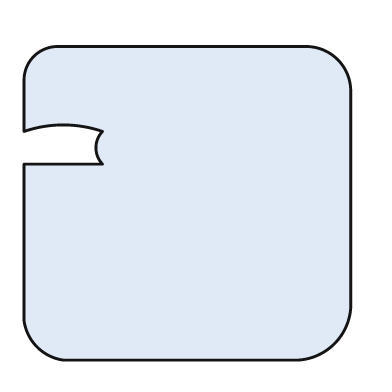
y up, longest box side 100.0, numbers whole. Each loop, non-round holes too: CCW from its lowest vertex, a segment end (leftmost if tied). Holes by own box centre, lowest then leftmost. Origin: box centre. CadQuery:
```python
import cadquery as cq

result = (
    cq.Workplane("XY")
    .moveTo(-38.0, -48.0)
    .lineTo(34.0, -48.0)
    .threePointArc((45.0, -43.0), (50.0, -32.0))
    .lineTo(50.0, 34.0)
    .threePointArc((46.0, 44.0), (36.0, 48.0))
    .lineTo(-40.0, 48.0)
    .threePointArc((-47.0, 45.0), (-50.0, 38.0))
    .lineTo(-50.0, 22.0)
    .threePointArc((-38.0, 24.0), (-26.0, 22.0))
    .threePointArc((-28.0, 17.0), (-26.0, 12.0))
    .lineTo(-50.0, 12.0)
    .lineTo(-50.0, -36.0)
    .threePointArc((-46.0, -44.0), (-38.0, -48.0))
    .close()
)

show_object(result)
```